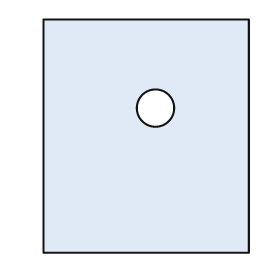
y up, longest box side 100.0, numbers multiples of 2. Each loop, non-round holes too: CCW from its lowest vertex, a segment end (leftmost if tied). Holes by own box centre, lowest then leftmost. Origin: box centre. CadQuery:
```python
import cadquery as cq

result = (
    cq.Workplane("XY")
    .moveTo(-44.0, -50.0)
    .lineTo(44.0, -50.0)
    .lineTo(44.0, 50.0)
    .lineTo(-44.0, 50.0)
    .close()
    .moveTo(4.0, 12.0)
    .circle(8.0)
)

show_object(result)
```